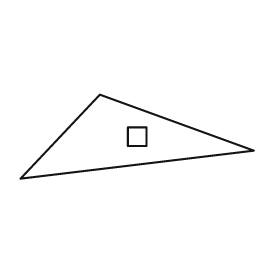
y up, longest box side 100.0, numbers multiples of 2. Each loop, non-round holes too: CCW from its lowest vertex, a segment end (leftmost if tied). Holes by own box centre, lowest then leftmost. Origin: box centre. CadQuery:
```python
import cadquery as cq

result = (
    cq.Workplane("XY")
    .moveTo(-50.0, -18.0)
    .lineTo(50.0, -6.0)
    .lineTo(-16.0, 18.0)
    .close()
    .moveTo(-4.0, -4.0)
    .lineTo(4.0, -4.0)
    .lineTo(4.0, 4.0)
    .lineTo(-4.0, 4.0)
    .close()
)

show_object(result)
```